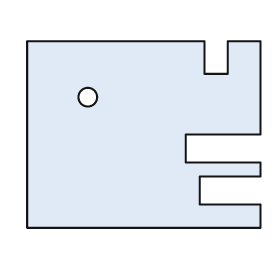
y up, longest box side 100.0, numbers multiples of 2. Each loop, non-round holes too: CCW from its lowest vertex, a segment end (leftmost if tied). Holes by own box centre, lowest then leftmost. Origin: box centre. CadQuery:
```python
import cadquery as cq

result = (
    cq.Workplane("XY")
    .moveTo(-50.0, -40.0)
    .lineTo(50.0, -40.0)
    .lineTo(50.0, -30.0)
    .lineTo(24.0, -30.0)
    .lineTo(24.0, -18.0)
    .lineTo(50.0, -18.0)
    .lineTo(50.0, -12.0)
    .lineTo(18.0, -12.0)
    .lineTo(18.0, 0.0)
    .lineTo(50.0, 0.0)
    .lineTo(50.0, 40.0)
    .lineTo(36.0, 40.0)
    .lineTo(36.0, 26.0)
    .lineTo(26.0, 26.0)
    .lineTo(26.0, 40.0)
    .lineTo(-50.0, 40.0)
    .close()
    .moveTo(-24.0, 16.0)
    .circle(4.0)
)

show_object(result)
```